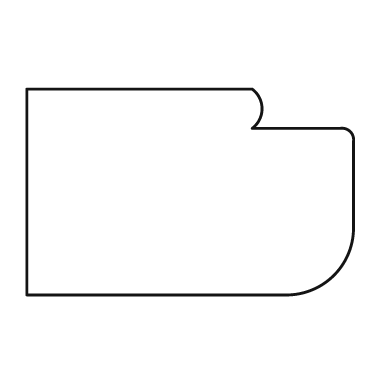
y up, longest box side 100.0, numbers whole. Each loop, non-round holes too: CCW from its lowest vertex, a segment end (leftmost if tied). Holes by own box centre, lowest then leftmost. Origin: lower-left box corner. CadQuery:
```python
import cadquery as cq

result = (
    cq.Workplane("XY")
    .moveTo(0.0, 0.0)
    .lineTo(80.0, 0.0)
    .threePointArc((94.0, 6.0), (100.0, 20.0))
    .lineTo(100.0, 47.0)
    .threePointArc((99.0, 50.0), (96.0, 51.0))
    .lineTo(69.0, 51.0)
    .threePointArc((72.0, 57.0), (69.0, 63.0))
    .lineTo(0.0, 63.0)
    .close()
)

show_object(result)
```